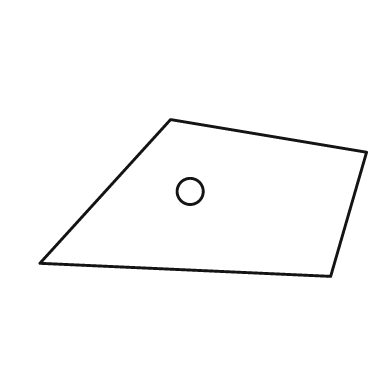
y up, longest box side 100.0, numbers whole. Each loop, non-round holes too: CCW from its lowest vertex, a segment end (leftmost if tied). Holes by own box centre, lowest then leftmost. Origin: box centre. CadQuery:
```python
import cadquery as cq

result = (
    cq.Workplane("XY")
    .moveTo(39.0, -24.0)
    .lineTo(50.0, 14.0)
    .lineTo(-10.0, 24.0)
    .lineTo(-50.0, -20.0)
    .close()
    .moveTo(-4.0, 2.0)
    .circle(4.0)
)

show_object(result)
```